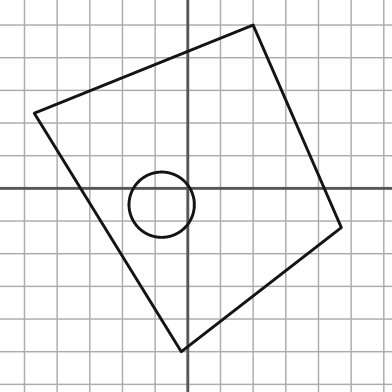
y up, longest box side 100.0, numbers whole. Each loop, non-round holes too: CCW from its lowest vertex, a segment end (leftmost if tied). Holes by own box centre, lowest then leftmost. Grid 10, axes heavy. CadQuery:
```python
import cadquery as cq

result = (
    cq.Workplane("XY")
    .moveTo(-2.0, -50.0)
    .lineTo(47.0, -12.0)
    .lineTo(20.0, 50.0)
    .lineTo(-47.0, 23.0)
    .close()
    .moveTo(-8.0, -5.0)
    .circle(10.0)
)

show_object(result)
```